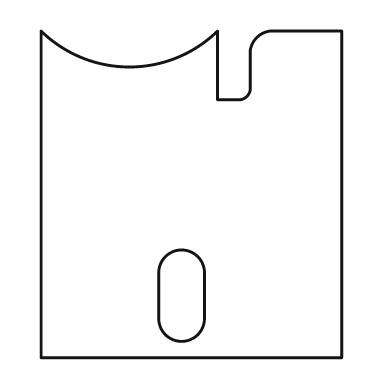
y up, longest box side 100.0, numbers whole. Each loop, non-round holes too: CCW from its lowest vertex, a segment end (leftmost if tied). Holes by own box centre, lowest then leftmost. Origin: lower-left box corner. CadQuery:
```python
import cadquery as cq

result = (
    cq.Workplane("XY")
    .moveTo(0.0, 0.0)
    .lineTo(92.0, 0.0)
    .lineTo(92.0, 100.0)
    .lineTo(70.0, 100.0)
    .threePointArc((66.0, 98.0), (64.0, 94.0))
    .lineTo(64.0, 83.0)
    .threePointArc((63.0, 80.0), (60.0, 79.0))
    .lineTo(54.0, 79.0)
    .lineTo(54.0, 100.0)
    .threePointArc((27.0, 89.0), (0.0, 100.0))
    .close()
    .moveTo(36.0, 12.0)
    .threePointArc((43.0, 5.0), (50.0, 12.0))
    .lineTo(50.0, 26.0)
    .threePointArc((43.0, 33.0), (36.0, 26.0))
    .close()
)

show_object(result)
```